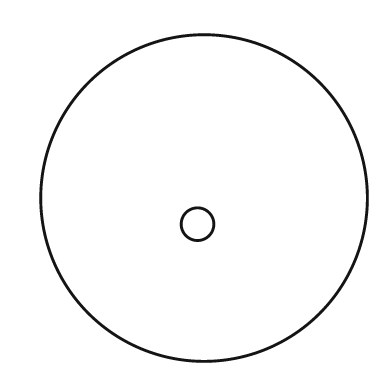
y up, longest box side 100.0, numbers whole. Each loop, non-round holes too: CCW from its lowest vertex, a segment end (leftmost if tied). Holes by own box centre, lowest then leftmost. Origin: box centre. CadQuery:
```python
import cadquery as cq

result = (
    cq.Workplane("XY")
    .moveTo(0.0, 0.0)
    .circle(50.0)
    .moveTo(-2.0, -8.0)
    .circle(5.0)
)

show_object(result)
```